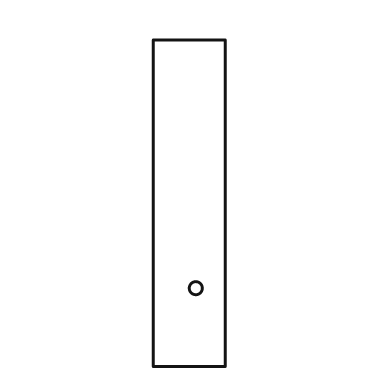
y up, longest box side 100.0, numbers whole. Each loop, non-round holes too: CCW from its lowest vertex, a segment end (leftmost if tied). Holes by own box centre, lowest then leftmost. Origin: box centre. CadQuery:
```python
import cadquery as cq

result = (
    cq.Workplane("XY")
    .moveTo(-11.0, -50.0)
    .lineTo(11.0, -50.0)
    .lineTo(11.0, 50.0)
    .lineTo(-11.0, 50.0)
    .close()
    .moveTo(2.0, -26.0)
    .circle(2.0)
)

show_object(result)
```